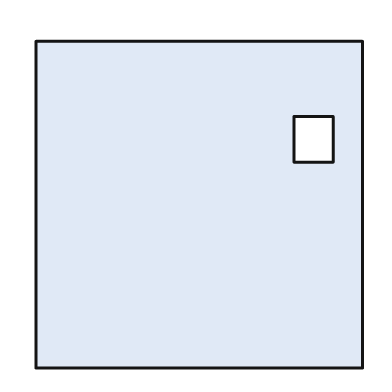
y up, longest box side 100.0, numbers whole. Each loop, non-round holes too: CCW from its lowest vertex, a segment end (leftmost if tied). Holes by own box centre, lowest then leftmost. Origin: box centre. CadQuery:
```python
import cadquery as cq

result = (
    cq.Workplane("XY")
    .moveTo(-50.0, -50.0)
    .lineTo(50.0, -50.0)
    .lineTo(50.0, 50.0)
    .lineTo(-50.0, 50.0)
    .close()
    .moveTo(29.0, 13.0)
    .lineTo(41.0, 13.0)
    .lineTo(41.0, 27.0)
    .lineTo(29.0, 27.0)
    .close()
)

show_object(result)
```